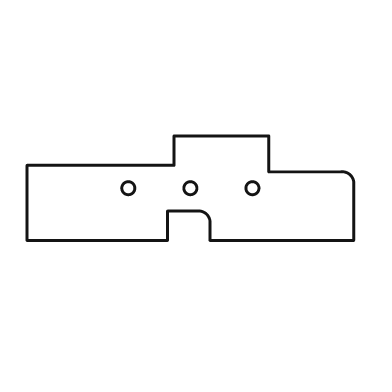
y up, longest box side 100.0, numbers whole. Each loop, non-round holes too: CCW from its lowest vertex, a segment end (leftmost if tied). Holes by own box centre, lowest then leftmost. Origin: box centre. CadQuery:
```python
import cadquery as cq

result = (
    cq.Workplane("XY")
    .moveTo(-50.0, -16.0)
    .lineTo(-7.0, -16.0)
    .lineTo(-7.0, -7.0)
    .lineTo(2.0, -7.0)
    .threePointArc((5.0, -8.0), (6.0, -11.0))
    .lineTo(6.0, -16.0)
    .lineTo(50.0, -16.0)
    .lineTo(50.0, 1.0)
    .threePointArc((49.0, 4.0), (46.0, 5.0))
    .lineTo(24.0, 5.0)
    .lineTo(24.0, 16.0)
    .lineTo(-5.0, 16.0)
    .lineTo(-5.0, 7.0)
    .lineTo(-50.0, 7.0)
    .close()
    .moveTo(-19.0, 0.0)
    .circle(2.0)
    .moveTo(0.0, 0.0)
    .circle(2.0)
    .moveTo(19.0, 0.0)
    .circle(2.0)
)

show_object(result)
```